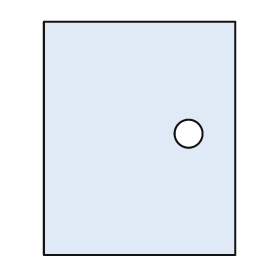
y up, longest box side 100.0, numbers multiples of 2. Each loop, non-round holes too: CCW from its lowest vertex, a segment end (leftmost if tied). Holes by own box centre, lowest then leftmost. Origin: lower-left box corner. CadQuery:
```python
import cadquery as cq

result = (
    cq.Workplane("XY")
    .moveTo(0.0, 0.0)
    .lineTo(82.0, 0.0)
    .lineTo(82.0, 100.0)
    .lineTo(0.0, 100.0)
    .close()
    .moveTo(62.0, 52.0)
    .circle(6.0)
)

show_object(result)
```